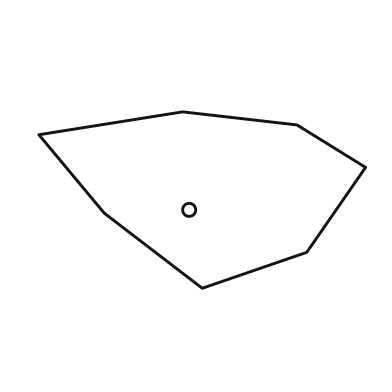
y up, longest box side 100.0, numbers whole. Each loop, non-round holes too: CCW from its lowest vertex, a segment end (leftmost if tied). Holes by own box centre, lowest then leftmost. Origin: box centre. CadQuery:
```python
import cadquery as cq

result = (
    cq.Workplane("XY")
    .moveTo(0.0, -27.0)
    .lineTo(32.0, -16.0)
    .lineTo(50.0, 10.0)
    .lineTo(29.0, 23.0)
    .lineTo(-6.0, 27.0)
    .lineTo(-50.0, 20.0)
    .lineTo(-30.0, -4.0)
    .close()
    .moveTo(-4.0, -3.0)
    .circle(2.0)
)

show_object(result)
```